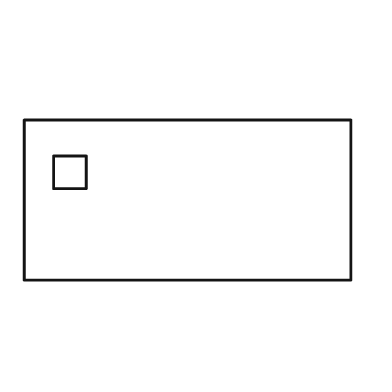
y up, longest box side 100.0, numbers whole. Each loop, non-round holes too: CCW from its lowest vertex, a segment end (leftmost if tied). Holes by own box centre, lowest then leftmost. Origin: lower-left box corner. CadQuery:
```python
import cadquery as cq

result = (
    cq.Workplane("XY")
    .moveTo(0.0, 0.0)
    .lineTo(100.0, 0.0)
    .lineTo(100.0, 49.0)
    .lineTo(0.0, 49.0)
    .close()
    .moveTo(9.0, 28.0)
    .lineTo(19.0, 28.0)
    .lineTo(19.0, 38.0)
    .lineTo(9.0, 38.0)
    .close()
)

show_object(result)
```